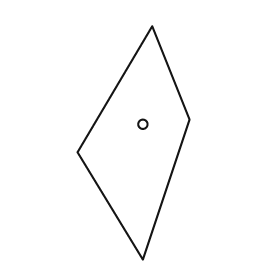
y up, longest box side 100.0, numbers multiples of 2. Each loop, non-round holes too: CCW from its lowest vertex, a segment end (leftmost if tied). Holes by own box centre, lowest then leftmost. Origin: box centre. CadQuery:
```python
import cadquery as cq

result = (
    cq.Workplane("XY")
    .moveTo(4.0, -50.0)
    .lineTo(24.0, 10.0)
    .lineTo(8.0, 50.0)
    .lineTo(-24.0, -4.0)
    .close()
    .moveTo(4.0, 8.0)
    .circle(2.0)
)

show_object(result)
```